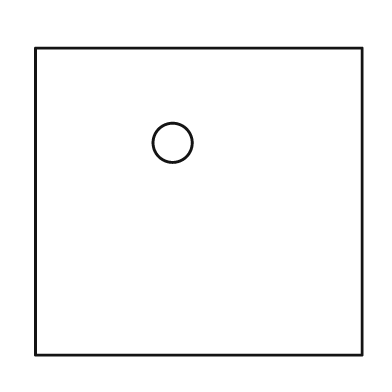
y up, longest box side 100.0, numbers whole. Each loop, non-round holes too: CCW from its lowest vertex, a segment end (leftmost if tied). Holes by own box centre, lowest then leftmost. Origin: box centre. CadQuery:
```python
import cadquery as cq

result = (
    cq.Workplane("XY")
    .moveTo(-50.0, -47.0)
    .lineTo(50.0, -47.0)
    .lineTo(50.0, 47.0)
    .lineTo(-50.0, 47.0)
    .close()
    .moveTo(-8.0, 18.0)
    .circle(6.0)
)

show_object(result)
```